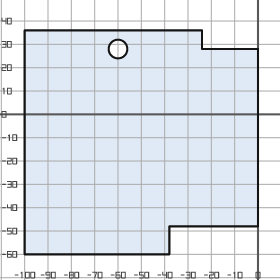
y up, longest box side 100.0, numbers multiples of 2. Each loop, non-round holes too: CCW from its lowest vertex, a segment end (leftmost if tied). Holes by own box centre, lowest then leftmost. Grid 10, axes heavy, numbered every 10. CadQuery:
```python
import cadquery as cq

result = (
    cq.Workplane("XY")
    .moveTo(-100.0, -60.0)
    .lineTo(-38.0, -60.0)
    .lineTo(-38.0, -48.0)
    .lineTo(0.0, -48.0)
    .lineTo(0.0, 28.0)
    .lineTo(-24.0, 28.0)
    .lineTo(-24.0, 36.0)
    .lineTo(-100.0, 36.0)
    .close()
    .moveTo(-60.0, 28.0)
    .circle(4.0)
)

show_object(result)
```